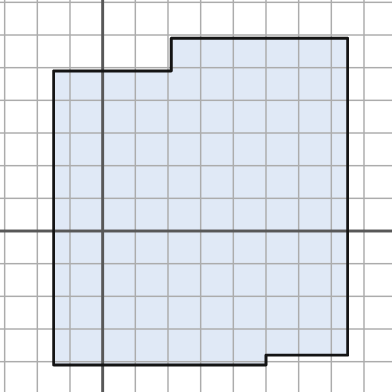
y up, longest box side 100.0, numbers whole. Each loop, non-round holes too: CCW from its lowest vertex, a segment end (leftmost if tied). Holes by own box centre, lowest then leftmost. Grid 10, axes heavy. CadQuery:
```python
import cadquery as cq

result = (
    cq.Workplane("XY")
    .moveTo(-15.0, -41.0)
    .lineTo(50.0, -41.0)
    .lineTo(50.0, -38.0)
    .lineTo(75.0, -38.0)
    .lineTo(75.0, 59.0)
    .lineTo(21.0, 59.0)
    .lineTo(21.0, 49.0)
    .lineTo(-15.0, 49.0)
    .close()
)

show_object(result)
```